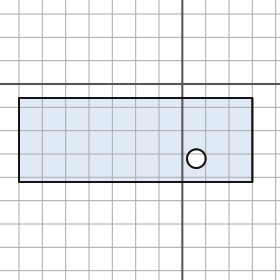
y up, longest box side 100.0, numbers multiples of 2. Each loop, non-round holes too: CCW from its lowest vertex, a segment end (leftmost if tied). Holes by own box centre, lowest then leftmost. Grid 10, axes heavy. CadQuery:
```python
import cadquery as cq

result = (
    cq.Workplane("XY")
    .moveTo(-70.0, -42.0)
    .lineTo(30.0, -42.0)
    .lineTo(30.0, -6.0)
    .lineTo(-70.0, -6.0)
    .close()
    .moveTo(6.0, -32.0)
    .circle(4.0)
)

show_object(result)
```